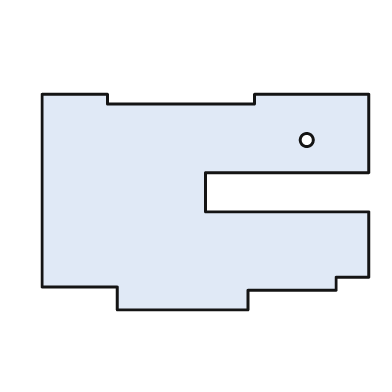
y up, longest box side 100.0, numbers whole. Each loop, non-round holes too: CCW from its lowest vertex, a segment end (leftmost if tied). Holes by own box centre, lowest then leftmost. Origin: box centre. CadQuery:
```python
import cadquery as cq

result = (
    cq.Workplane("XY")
    .moveTo(-27.0, -33.0)
    .lineTo(13.0, -33.0)
    .lineTo(13.0, -27.0)
    .lineTo(40.0, -27.0)
    .lineTo(40.0, -23.0)
    .lineTo(50.0, -23.0)
    .lineTo(50.0, -3.0)
    .lineTo(0.0, -3.0)
    .lineTo(0.0, 9.0)
    .lineTo(50.0, 9.0)
    .lineTo(50.0, 33.0)
    .lineTo(15.0, 33.0)
    .lineTo(15.0, 30.0)
    .lineTo(-30.0, 30.0)
    .lineTo(-30.0, 33.0)
    .lineTo(-50.0, 33.0)
    .lineTo(-50.0, -26.0)
    .lineTo(-27.0, -26.0)
    .close()
    .moveTo(31.0, 19.0)
    .circle(2.0)
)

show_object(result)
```